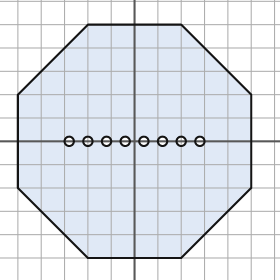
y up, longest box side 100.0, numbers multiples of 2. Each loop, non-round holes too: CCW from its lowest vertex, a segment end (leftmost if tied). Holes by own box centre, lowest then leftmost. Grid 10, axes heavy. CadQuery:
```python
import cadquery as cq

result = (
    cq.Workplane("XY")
    .moveTo(-20.0, -50.0)
    .lineTo(20.0, -50.0)
    .lineTo(50.0, -20.0)
    .lineTo(50.0, 20.0)
    .lineTo(20.0, 50.0)
    .lineTo(-20.0, 50.0)
    .lineTo(-50.0, 20.0)
    .lineTo(-50.0, -20.0)
    .close()
    .moveTo(-28.0, 0.0)
    .circle(2.0)
    .moveTo(-20.0, 0.0)
    .circle(2.0)
    .moveTo(-12.0, 0.0)
    .circle(2.0)
    .moveTo(-4.0, 0.0)
    .circle(2.0)
    .moveTo(4.0, 0.0)
    .circle(2.0)
    .moveTo(12.0, 0.0)
    .circle(2.0)
    .moveTo(20.0, 0.0)
    .circle(2.0)
    .moveTo(28.0, 0.0)
    .circle(2.0)
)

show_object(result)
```